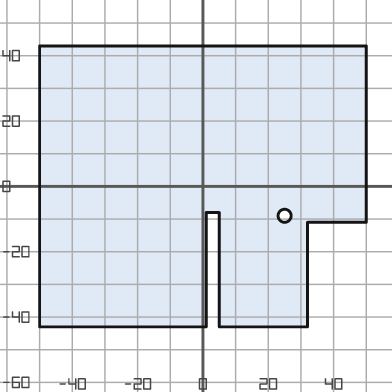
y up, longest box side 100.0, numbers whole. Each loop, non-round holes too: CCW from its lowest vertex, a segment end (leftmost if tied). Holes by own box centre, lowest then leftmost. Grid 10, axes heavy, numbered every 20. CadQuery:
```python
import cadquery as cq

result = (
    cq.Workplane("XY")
    .moveTo(-50.0, -43.0)
    .lineTo(1.0, -43.0)
    .lineTo(1.0, -8.0)
    .lineTo(5.0, -8.0)
    .lineTo(5.0, -43.0)
    .lineTo(32.0, -43.0)
    .lineTo(32.0, -11.0)
    .lineTo(50.0, -11.0)
    .lineTo(50.0, 43.0)
    .lineTo(-50.0, 43.0)
    .close()
    .moveTo(25.0, -9.0)
    .circle(2.0)
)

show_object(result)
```